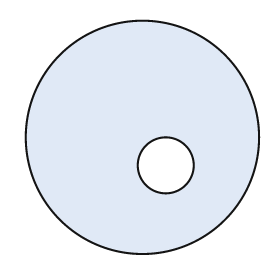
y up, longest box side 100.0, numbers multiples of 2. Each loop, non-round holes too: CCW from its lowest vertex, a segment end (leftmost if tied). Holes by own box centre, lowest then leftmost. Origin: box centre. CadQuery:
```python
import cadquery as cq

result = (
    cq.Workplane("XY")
    .moveTo(0.0, 0.0)
    .circle(50.0)
    .moveTo(10.0, -12.0)
    .circle(12.0)
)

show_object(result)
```